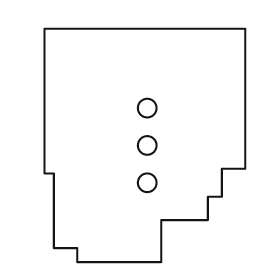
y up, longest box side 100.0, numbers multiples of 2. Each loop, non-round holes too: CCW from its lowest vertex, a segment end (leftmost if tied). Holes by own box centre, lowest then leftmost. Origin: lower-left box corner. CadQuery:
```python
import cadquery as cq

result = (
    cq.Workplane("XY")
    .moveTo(14.0, 0.0)
    .lineTo(50.0, 0.0)
    .lineTo(50.0, 18.0)
    .lineTo(70.0, 18.0)
    .lineTo(70.0, 28.0)
    .lineTo(76.0, 28.0)
    .lineTo(76.0, 40.0)
    .lineTo(86.0, 40.0)
    .lineTo(86.0, 100.0)
    .lineTo(0.0, 100.0)
    .lineTo(0.0, 38.0)
    .lineTo(4.0, 38.0)
    .lineTo(4.0, 6.0)
    .lineTo(14.0, 6.0)
    .close()
    .moveTo(44.0, 34.0)
    .circle(4.0)
    .moveTo(44.0, 50.0)
    .circle(4.0)
    .moveTo(44.0, 66.0)
    .circle(4.0)
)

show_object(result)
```